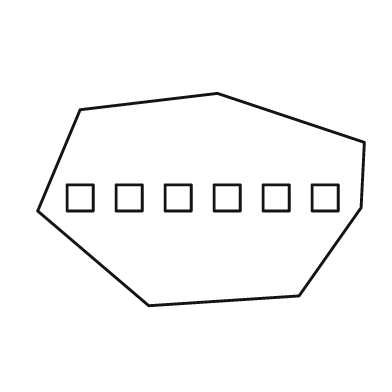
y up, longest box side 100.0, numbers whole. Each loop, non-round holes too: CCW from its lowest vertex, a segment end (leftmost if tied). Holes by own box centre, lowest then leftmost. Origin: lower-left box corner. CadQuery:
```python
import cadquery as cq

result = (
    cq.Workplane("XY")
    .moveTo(34.0, 0.0)
    .lineTo(80.0, 3.0)
    .lineTo(99.0, 30.0)
    .lineTo(100.0, 50.0)
    .lineTo(55.0, 65.0)
    .lineTo(13.0, 60.0)
    .lineTo(0.0, 29.0)
    .close()
    .moveTo(9.0, 29.0)
    .lineTo(17.0, 29.0)
    .lineTo(17.0, 37.0)
    .lineTo(9.0, 37.0)
    .close()
    .moveTo(24.0, 29.0)
    .lineTo(32.0, 29.0)
    .lineTo(32.0, 37.0)
    .lineTo(24.0, 37.0)
    .close()
    .moveTo(39.0, 29.0)
    .lineTo(47.0, 29.0)
    .lineTo(47.0, 37.0)
    .lineTo(39.0, 37.0)
    .close()
    .moveTo(54.0, 29.0)
    .lineTo(62.0, 29.0)
    .lineTo(62.0, 37.0)
    .lineTo(54.0, 37.0)
    .close()
    .moveTo(69.0, 29.0)
    .lineTo(77.0, 29.0)
    .lineTo(77.0, 37.0)
    .lineTo(69.0, 37.0)
    .close()
    .moveTo(84.0, 29.0)
    .lineTo(92.0, 29.0)
    .lineTo(92.0, 37.0)
    .lineTo(84.0, 37.0)
    .close()
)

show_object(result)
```